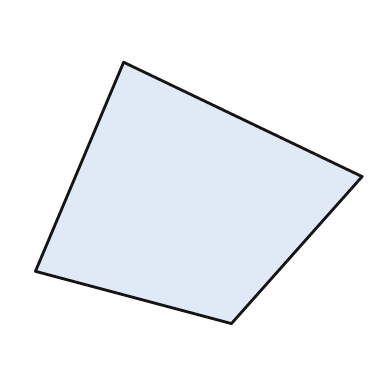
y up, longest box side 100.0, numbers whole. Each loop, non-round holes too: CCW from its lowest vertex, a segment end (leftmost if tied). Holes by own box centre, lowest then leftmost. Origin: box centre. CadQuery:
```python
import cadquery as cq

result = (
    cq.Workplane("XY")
    .moveTo(10.0, -40.0)
    .lineTo(50.0, 5.0)
    .lineTo(-23.0, 40.0)
    .lineTo(-50.0, -24.0)
    .close()
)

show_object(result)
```